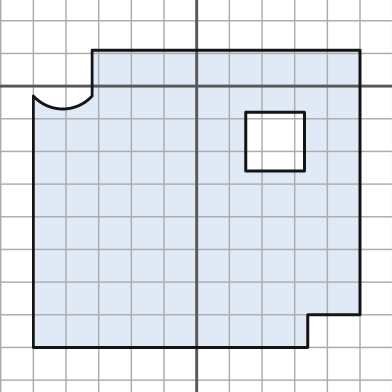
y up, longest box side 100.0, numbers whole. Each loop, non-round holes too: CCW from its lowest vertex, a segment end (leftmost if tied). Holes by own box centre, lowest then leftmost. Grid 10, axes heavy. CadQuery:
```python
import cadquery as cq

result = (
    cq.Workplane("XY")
    .moveTo(-50.0, -80.0)
    .lineTo(34.0, -80.0)
    .lineTo(34.0, -70.0)
    .lineTo(50.0, -70.0)
    .lineTo(50.0, 11.0)
    .lineTo(-32.0, 11.0)
    .lineTo(-32.0, -3.0)
    .threePointArc((-41.0, -7.0), (-50.0, -3.0))
    .close()
    .moveTo(15.0, -26.0)
    .lineTo(33.0, -26.0)
    .lineTo(33.0, -8.0)
    .lineTo(15.0, -8.0)
    .close()
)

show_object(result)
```